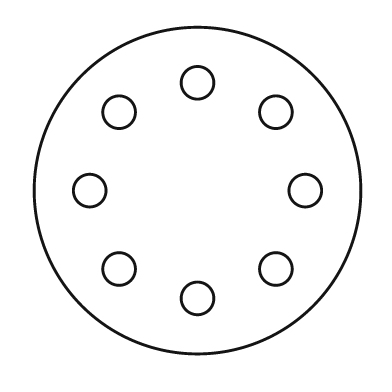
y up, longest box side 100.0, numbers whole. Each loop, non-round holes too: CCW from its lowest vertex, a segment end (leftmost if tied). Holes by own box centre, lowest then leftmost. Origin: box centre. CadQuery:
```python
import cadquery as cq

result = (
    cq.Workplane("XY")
    .moveTo(0.0, 0.0)
    .circle(50.0)
    .moveTo(0.0, -33.0)
    .circle(5.0)
    .moveTo(-24.0, -24.0)
    .circle(5.0)
    .moveTo(24.0, -24.0)
    .circle(5.0)
    .moveTo(-33.0, 0.0)
    .circle(5.0)
    .moveTo(33.0, 0.0)
    .circle(5.0)
    .moveTo(-24.0, 24.0)
    .circle(5.0)
    .moveTo(24.0, 24.0)
    .circle(5.0)
    .moveTo(0.0, 33.0)
    .circle(5.0)
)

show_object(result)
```